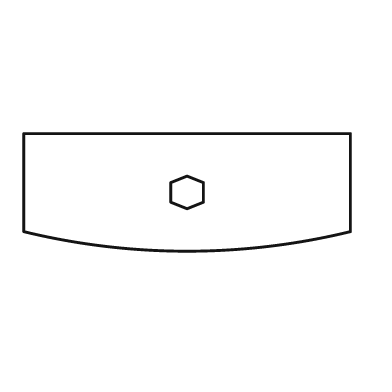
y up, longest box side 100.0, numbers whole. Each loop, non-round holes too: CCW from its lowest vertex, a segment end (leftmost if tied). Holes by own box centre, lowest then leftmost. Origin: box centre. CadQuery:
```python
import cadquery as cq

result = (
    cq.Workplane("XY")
    .moveTo(-50.0, -12.0)
    .threePointArc((0.0, -18.0), (50.0, -12.0))
    .lineTo(50.0, 18.0)
    .lineTo(-50.0, 18.0)
    .close()
    .moveTo(0.0, -5.0)
    .lineTo(5.0, -3.0)
    .lineTo(5.0, 3.0)
    .lineTo(0.0, 5.0)
    .lineTo(-5.0, 3.0)
    .lineTo(-5.0, -3.0)
    .close()
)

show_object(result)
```